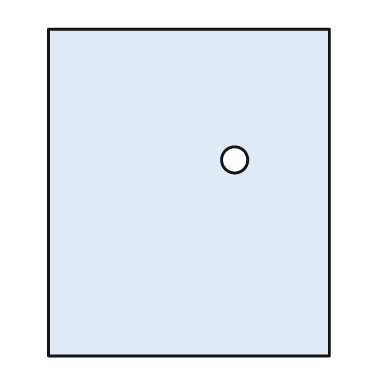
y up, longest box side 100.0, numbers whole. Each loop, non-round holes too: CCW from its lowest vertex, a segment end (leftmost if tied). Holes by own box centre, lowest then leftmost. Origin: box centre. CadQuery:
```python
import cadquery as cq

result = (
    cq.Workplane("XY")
    .moveTo(-43.0, -50.0)
    .lineTo(43.0, -50.0)
    .lineTo(43.0, 50.0)
    .lineTo(-43.0, 50.0)
    .close()
    .moveTo(14.0, 10.0)
    .circle(4.0)
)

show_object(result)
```